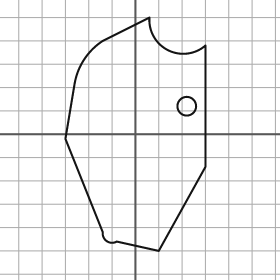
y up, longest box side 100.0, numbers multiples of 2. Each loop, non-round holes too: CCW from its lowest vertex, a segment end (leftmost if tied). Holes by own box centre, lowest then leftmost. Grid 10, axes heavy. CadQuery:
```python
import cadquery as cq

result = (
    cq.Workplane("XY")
    .moveTo(10.0, -50.0)
    .lineTo(30.0, -14.0)
    .lineTo(30.0, 38.0)
    .threePointArc((14.0, 36.0), (6.0, 50.0))
    .lineTo(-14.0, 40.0)
    .threePointArc((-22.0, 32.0), (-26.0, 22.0))
    .lineTo(-30.0, -2.0)
    .lineTo(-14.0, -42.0)
    .threePointArc((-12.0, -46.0), (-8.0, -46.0))
    .close()
    .moveTo(22.0, 12.0)
    .circle(4.0)
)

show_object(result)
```